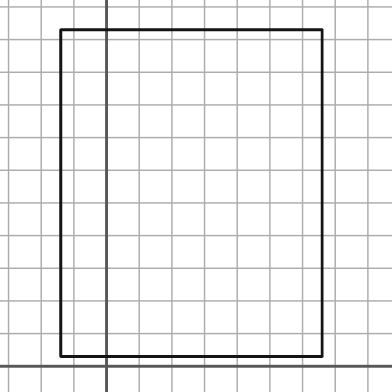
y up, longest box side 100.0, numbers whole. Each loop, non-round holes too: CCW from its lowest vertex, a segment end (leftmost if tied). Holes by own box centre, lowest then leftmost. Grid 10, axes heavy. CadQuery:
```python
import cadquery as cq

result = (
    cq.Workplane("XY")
    .moveTo(-14.0, 3.0)
    .lineTo(66.0, 3.0)
    .lineTo(66.0, 103.0)
    .lineTo(-14.0, 103.0)
    .close()
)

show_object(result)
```